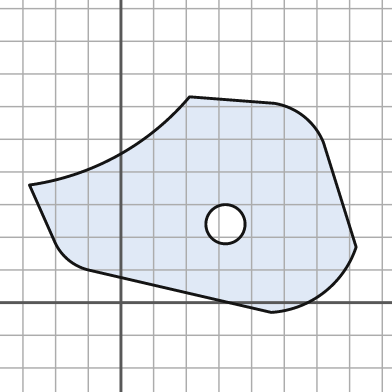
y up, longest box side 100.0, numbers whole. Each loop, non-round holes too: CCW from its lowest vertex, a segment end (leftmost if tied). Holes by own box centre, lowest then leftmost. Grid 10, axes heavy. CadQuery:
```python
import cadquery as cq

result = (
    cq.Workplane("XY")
    .moveTo(46.0, -3.0)
    .threePointArc((62.0, 3.0), (72.0, 17.0))
    .lineTo(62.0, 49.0)
    .threePointArc((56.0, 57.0), (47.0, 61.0))
    .lineTo(21.0, 63.0)
    .threePointArc((-1.0, 45.0), (-28.0, 36.0))
    .lineTo(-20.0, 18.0)
    .threePointArc((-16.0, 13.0), (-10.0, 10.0))
    .close()
    .moveTo(32.0, 24.0)
    .circle(6.0)
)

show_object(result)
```